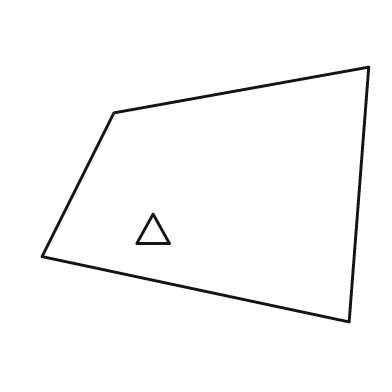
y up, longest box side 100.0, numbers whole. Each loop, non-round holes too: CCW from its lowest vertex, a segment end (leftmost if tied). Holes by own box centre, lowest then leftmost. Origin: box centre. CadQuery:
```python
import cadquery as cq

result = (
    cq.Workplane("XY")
    .moveTo(44.0, -39.0)
    .lineTo(50.0, 39.0)
    .lineTo(-28.0, 25.0)
    .lineTo(-50.0, -19.0)
    .close()
    .moveTo(-21.0, -15.0)
    .lineTo(-11.0, -15.0)
    .lineTo(-16.0, -6.0)
    .close()
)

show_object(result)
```